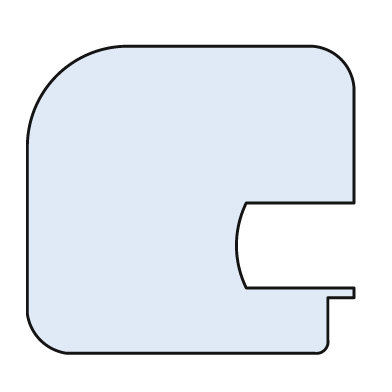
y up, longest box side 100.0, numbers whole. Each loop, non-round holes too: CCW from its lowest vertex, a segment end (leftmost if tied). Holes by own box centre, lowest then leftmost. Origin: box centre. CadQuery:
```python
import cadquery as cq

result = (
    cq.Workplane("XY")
    .moveTo(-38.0, -47.0)
    .lineTo(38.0, -47.0)
    .threePointArc((41.0, -46.0), (42.0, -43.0))
    .lineTo(42.0, -30.0)
    .lineTo(50.0, -30.0)
    .lineTo(50.0, -27.0)
    .lineTo(17.0, -27.0)
    .threePointArc((14.0, -14.0), (17.0, -1.0))
    .lineTo(50.0, -1.0)
    .lineTo(50.0, 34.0)
    .threePointArc((46.0, 43.0), (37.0, 47.0))
    .lineTo(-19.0, 47.0)
    .threePointArc((-41.0, 38.0), (-50.0, 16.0))
    .lineTo(-50.0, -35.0)
    .threePointArc((-46.0, -43.0), (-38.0, -47.0))
    .close()
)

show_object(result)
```